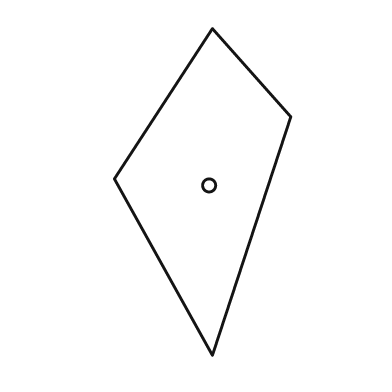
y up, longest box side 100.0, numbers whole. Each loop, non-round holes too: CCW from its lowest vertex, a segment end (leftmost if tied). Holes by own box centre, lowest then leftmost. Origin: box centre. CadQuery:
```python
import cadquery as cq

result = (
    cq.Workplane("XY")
    .moveTo(3.0, -50.0)
    .lineTo(27.0, 23.0)
    .lineTo(3.0, 50.0)
    .lineTo(-27.0, 4.0)
    .close()
    .moveTo(2.0, 2.0)
    .circle(2.0)
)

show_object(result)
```